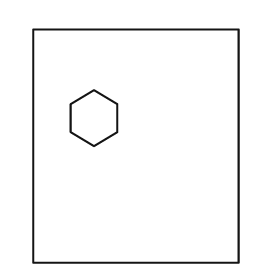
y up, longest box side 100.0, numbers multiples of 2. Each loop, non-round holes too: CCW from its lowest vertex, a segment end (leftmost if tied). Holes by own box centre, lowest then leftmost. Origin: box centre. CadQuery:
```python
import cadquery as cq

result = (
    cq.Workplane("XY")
    .moveTo(-44.0, -50.0)
    .lineTo(44.0, -50.0)
    .lineTo(44.0, 50.0)
    .lineTo(-44.0, 50.0)
    .close()
    .moveTo(-18.0, 0.0)
    .lineTo(-8.0, 6.0)
    .lineTo(-8.0, 18.0)
    .lineTo(-18.0, 24.0)
    .lineTo(-28.0, 18.0)
    .lineTo(-28.0, 6.0)
    .close()
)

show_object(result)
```